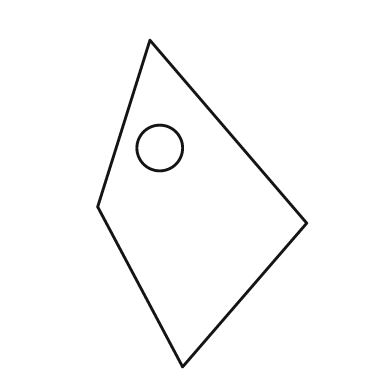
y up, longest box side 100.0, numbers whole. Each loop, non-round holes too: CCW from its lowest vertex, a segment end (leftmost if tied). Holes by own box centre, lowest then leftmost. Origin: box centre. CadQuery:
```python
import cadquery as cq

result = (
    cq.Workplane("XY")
    .moveTo(-6.0, -50.0)
    .lineTo(32.0, -6.0)
    .lineTo(-16.0, 50.0)
    .lineTo(-32.0, -1.0)
    .close()
    .moveTo(-13.0, 17.0)
    .circle(7.0)
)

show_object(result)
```